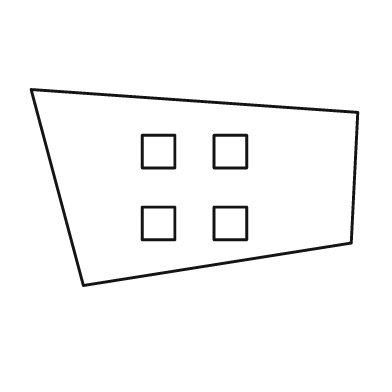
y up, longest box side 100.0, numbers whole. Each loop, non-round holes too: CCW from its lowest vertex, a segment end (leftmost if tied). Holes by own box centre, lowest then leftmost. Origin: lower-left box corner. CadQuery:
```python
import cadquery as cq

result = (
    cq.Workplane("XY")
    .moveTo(16.0, 0.0)
    .lineTo(98.0, 13.0)
    .lineTo(100.0, 53.0)
    .lineTo(0.0, 60.0)
    .close()
    .moveTo(34.0, 14.0)
    .lineTo(44.0, 14.0)
    .lineTo(44.0, 24.0)
    .lineTo(34.0, 24.0)
    .close()
    .moveTo(56.0, 14.0)
    .lineTo(66.0, 14.0)
    .lineTo(66.0, 24.0)
    .lineTo(56.0, 24.0)
    .close()
    .moveTo(34.0, 36.0)
    .lineTo(44.0, 36.0)
    .lineTo(44.0, 46.0)
    .lineTo(34.0, 46.0)
    .close()
    .moveTo(56.0, 36.0)
    .lineTo(66.0, 36.0)
    .lineTo(66.0, 46.0)
    .lineTo(56.0, 46.0)
    .close()
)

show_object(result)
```